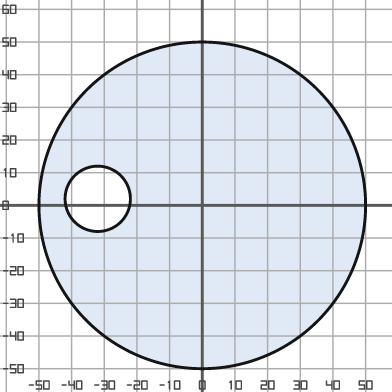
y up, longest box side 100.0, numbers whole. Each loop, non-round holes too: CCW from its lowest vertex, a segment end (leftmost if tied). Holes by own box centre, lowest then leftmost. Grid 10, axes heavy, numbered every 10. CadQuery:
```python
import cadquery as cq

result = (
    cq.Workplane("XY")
    .moveTo(0.0, 0.0)
    .circle(50.0)
    .moveTo(-32.0, 2.0)
    .circle(10.0)
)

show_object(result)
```